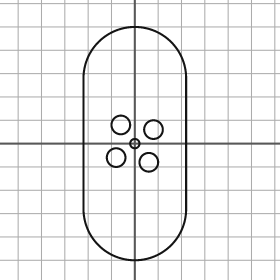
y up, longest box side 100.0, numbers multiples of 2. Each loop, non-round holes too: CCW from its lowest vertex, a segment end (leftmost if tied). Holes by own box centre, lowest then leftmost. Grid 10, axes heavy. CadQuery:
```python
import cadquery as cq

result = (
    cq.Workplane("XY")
    .moveTo(-22.0, -28.0)
    .threePointArc((0.0, -50.0), (22.0, -28.0))
    .lineTo(22.0, 28.0)
    .threePointArc((0.0, 50.0), (-22.0, 28.0))
    .close()
    .moveTo(6.0, -8.0)
    .circle(4.0)
    .moveTo(-8.0, -6.0)
    .circle(4.0)
    .moveTo(0.0, 0.0)
    .circle(2.0)
    .moveTo(8.0, 6.0)
    .circle(4.0)
    .moveTo(-6.0, 8.0)
    .circle(4.0)
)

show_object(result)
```